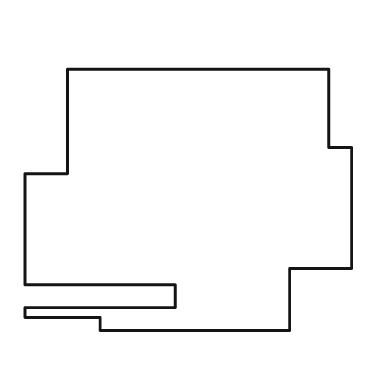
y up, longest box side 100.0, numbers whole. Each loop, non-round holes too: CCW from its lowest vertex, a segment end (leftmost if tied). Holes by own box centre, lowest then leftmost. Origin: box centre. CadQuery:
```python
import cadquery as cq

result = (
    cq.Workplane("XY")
    .moveTo(-27.0, -40.0)
    .lineTo(31.0, -40.0)
    .lineTo(31.0, -21.0)
    .lineTo(50.0, -21.0)
    .lineTo(50.0, 16.0)
    .lineTo(43.0, 16.0)
    .lineTo(43.0, 40.0)
    .lineTo(-37.0, 40.0)
    .lineTo(-37.0, 8.0)
    .lineTo(-50.0, 8.0)
    .lineTo(-50.0, -26.0)
    .lineTo(-4.0, -26.0)
    .lineTo(-4.0, -33.0)
    .lineTo(-50.0, -33.0)
    .lineTo(-50.0, -36.0)
    .lineTo(-27.0, -36.0)
    .close()
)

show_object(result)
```